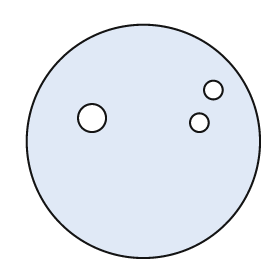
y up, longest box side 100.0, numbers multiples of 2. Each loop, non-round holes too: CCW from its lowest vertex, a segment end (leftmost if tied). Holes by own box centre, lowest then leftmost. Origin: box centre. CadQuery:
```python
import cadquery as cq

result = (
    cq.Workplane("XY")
    .moveTo(0.0, 0.0)
    .circle(50.0)
    .moveTo(24.0, 8.0)
    .circle(4.0)
    .moveTo(-22.0, 10.0)
    .circle(6.0)
    .moveTo(30.0, 22.0)
    .circle(4.0)
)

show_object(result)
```